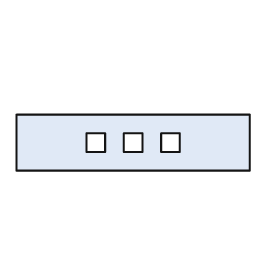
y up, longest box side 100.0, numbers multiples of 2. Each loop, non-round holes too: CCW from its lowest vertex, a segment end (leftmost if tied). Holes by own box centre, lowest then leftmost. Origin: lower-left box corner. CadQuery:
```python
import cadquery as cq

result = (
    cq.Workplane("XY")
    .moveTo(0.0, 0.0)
    .lineTo(100.0, 0.0)
    .lineTo(100.0, 24.0)
    .lineTo(0.0, 24.0)
    .close()
    .moveTo(30.0, 8.0)
    .lineTo(38.0, 8.0)
    .lineTo(38.0, 16.0)
    .lineTo(30.0, 16.0)
    .close()
    .moveTo(46.0, 8.0)
    .lineTo(54.0, 8.0)
    .lineTo(54.0, 16.0)
    .lineTo(46.0, 16.0)
    .close()
    .moveTo(62.0, 8.0)
    .lineTo(70.0, 8.0)
    .lineTo(70.0, 16.0)
    .lineTo(62.0, 16.0)
    .close()
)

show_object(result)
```